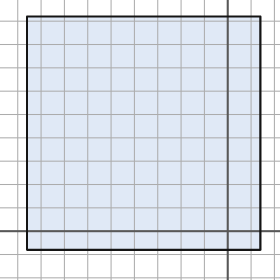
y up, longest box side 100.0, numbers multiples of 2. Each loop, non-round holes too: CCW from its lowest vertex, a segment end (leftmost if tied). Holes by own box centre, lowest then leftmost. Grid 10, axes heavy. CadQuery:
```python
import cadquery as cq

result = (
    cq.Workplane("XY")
    .moveTo(-86.0, -8.0)
    .lineTo(14.0, -8.0)
    .lineTo(14.0, 92.0)
    .lineTo(-86.0, 92.0)
    .close()
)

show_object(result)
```